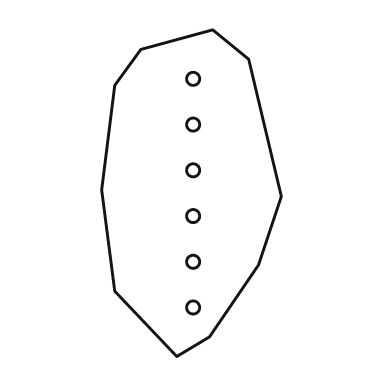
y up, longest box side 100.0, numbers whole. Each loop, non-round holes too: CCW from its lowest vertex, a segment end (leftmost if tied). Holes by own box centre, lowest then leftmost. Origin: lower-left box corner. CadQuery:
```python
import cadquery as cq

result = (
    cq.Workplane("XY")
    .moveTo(23.0, 0.0)
    .lineTo(33.0, 6.0)
    .lineTo(48.0, 28.0)
    .lineTo(55.0, 49.0)
    .lineTo(45.0, 91.0)
    .lineTo(34.0, 100.0)
    .lineTo(12.0, 94.0)
    .lineTo(4.0, 83.0)
    .lineTo(0.0, 51.0)
    .lineTo(4.0, 20.0)
    .close()
    .moveTo(28.0, 15.0)
    .circle(2.0)
    .moveTo(28.0, 29.0)
    .circle(2.0)
    .moveTo(28.0, 43.0)
    .circle(2.0)
    .moveTo(28.0, 57.0)
    .circle(2.0)
    .moveTo(28.0, 71.0)
    .circle(2.0)
    .moveTo(28.0, 85.0)
    .circle(2.0)
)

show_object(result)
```